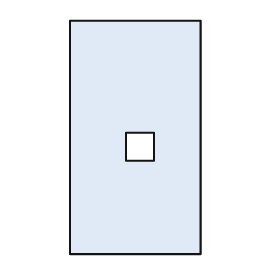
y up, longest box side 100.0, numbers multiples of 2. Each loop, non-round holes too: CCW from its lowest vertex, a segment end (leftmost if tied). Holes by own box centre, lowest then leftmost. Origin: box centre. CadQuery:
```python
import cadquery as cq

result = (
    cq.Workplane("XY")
    .moveTo(-28.0, -50.0)
    .lineTo(28.0, -50.0)
    .lineTo(28.0, 50.0)
    .lineTo(-28.0, 50.0)
    .close()
    .moveTo(-4.0, -10.0)
    .lineTo(8.0, -10.0)
    .lineTo(8.0, 2.0)
    .lineTo(-4.0, 2.0)
    .close()
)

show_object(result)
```